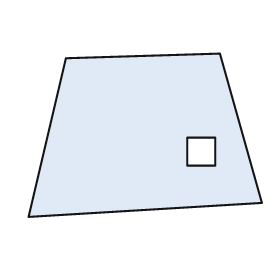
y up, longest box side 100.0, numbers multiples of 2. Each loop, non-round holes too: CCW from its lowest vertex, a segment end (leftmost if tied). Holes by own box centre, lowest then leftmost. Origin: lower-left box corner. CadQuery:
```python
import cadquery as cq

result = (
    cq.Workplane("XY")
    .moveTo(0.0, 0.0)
    .lineTo(100.0, 6.0)
    .lineTo(82.0, 70.0)
    .lineTo(16.0, 68.0)
    .close()
    .moveTo(68.0, 22.0)
    .lineTo(80.0, 22.0)
    .lineTo(80.0, 34.0)
    .lineTo(68.0, 34.0)
    .close()
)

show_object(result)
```